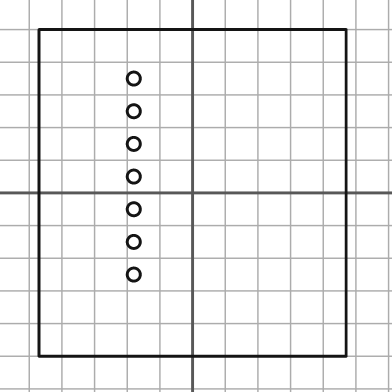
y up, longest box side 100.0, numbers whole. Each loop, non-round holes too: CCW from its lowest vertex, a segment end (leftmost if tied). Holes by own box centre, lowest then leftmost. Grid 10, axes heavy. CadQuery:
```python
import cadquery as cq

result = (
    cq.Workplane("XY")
    .moveTo(-47.0, -50.0)
    .lineTo(47.0, -50.0)
    .lineTo(47.0, 50.0)
    .lineTo(-47.0, 50.0)
    .close()
    .moveTo(-18.0, -25.0)
    .circle(2.0)
    .moveTo(-18.0, -15.0)
    .circle(2.0)
    .moveTo(-18.0, -5.0)
    .circle(2.0)
    .moveTo(-18.0, 5.0)
    .circle(2.0)
    .moveTo(-18.0, 15.0)
    .circle(2.0)
    .moveTo(-18.0, 25.0)
    .circle(2.0)
    .moveTo(-18.0, 35.0)
    .circle(2.0)
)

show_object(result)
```